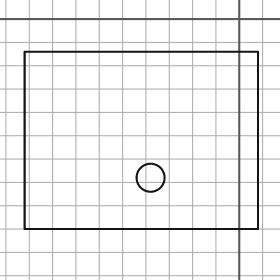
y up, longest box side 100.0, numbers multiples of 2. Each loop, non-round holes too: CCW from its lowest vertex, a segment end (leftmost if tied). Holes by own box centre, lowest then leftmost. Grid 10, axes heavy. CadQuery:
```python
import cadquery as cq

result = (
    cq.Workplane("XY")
    .moveTo(-92.0, -90.0)
    .lineTo(8.0, -90.0)
    .lineTo(8.0, -14.0)
    .lineTo(-92.0, -14.0)
    .close()
    .moveTo(-38.0, -68.0)
    .circle(6.0)
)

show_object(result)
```